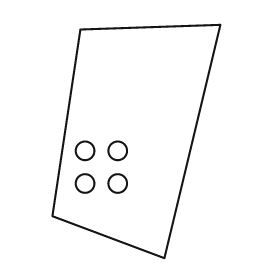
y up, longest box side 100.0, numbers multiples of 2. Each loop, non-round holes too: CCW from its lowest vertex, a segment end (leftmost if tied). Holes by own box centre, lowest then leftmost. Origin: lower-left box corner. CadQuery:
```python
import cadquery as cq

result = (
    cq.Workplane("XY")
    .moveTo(48.0, 0.0)
    .lineTo(72.0, 100.0)
    .lineTo(12.0, 98.0)
    .lineTo(0.0, 18.0)
    .close()
    .moveTo(14.0, 32.0)
    .circle(4.0)
    .moveTo(28.0, 32.0)
    .circle(4.0)
    .moveTo(14.0, 46.0)
    .circle(4.0)
    .moveTo(28.0, 46.0)
    .circle(4.0)
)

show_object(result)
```